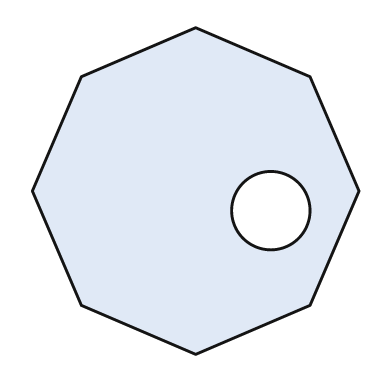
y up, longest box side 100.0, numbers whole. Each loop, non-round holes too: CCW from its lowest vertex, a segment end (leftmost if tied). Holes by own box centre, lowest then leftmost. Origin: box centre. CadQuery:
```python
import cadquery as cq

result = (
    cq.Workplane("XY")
    .moveTo(0.0, -50.0)
    .lineTo(35.0, -35.0)
    .lineTo(50.0, 0.0)
    .lineTo(35.0, 35.0)
    .lineTo(0.0, 50.0)
    .lineTo(-35.0, 35.0)
    .lineTo(-50.0, 0.0)
    .lineTo(-35.0, -35.0)
    .close()
    .moveTo(23.0, -6.0)
    .circle(12.0)
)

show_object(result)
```